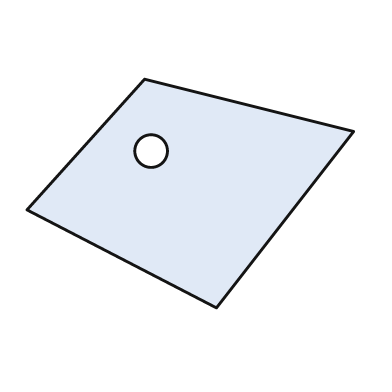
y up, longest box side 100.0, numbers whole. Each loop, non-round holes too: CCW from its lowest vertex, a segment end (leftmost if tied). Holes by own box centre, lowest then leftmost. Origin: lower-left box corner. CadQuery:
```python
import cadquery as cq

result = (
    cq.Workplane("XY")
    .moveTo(58.0, 0.0)
    .lineTo(100.0, 54.0)
    .lineTo(36.0, 70.0)
    .lineTo(0.0, 30.0)
    .close()
    .moveTo(38.0, 48.0)
    .circle(5.0)
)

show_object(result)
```